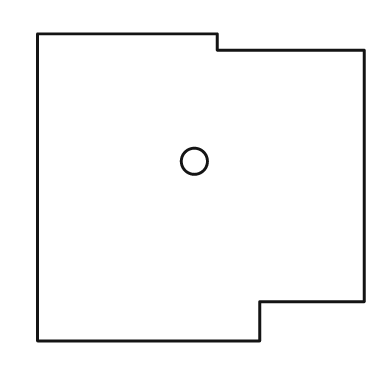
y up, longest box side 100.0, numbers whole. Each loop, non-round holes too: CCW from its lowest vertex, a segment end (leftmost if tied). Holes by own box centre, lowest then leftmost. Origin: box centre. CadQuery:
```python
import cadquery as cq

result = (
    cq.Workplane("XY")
    .moveTo(-50.0, -47.0)
    .lineTo(18.0, -47.0)
    .lineTo(18.0, -35.0)
    .lineTo(50.0, -35.0)
    .lineTo(50.0, 42.0)
    .lineTo(5.0, 42.0)
    .lineTo(5.0, 47.0)
    .lineTo(-50.0, 47.0)
    .close()
    .moveTo(-2.0, 8.0)
    .circle(4.0)
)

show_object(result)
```